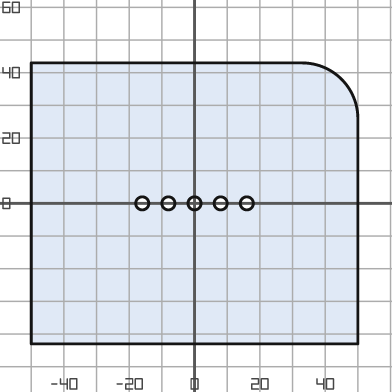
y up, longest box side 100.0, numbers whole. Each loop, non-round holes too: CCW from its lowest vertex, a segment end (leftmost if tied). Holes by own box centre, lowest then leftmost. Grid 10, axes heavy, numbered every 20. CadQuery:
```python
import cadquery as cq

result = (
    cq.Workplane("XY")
    .moveTo(-50.0, -43.0)
    .lineTo(50.0, -43.0)
    .lineTo(50.0, 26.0)
    .threePointArc((45.0, 38.0), (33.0, 43.0))
    .lineTo(-50.0, 43.0)
    .close()
    .moveTo(-16.0, 0.0)
    .circle(2.0)
    .moveTo(-8.0, 0.0)
    .circle(2.0)
    .moveTo(0.0, 0.0)
    .circle(2.0)
    .moveTo(8.0, 0.0)
    .circle(2.0)
    .moveTo(16.0, 0.0)
    .circle(2.0)
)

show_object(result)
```